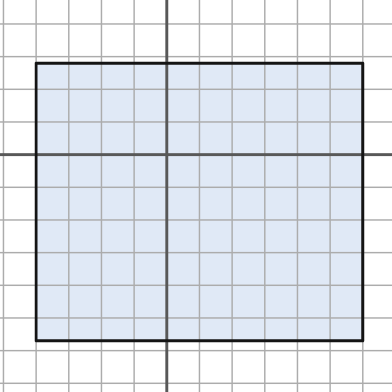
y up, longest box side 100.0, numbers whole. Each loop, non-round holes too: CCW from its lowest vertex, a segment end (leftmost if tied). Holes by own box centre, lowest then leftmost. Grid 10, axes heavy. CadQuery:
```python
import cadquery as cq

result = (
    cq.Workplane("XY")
    .moveTo(-40.0, -57.0)
    .lineTo(60.0, -57.0)
    .lineTo(60.0, 28.0)
    .lineTo(-40.0, 28.0)
    .close()
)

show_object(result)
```